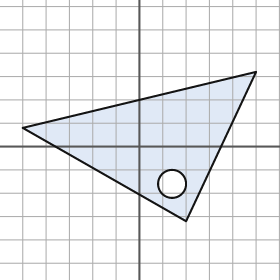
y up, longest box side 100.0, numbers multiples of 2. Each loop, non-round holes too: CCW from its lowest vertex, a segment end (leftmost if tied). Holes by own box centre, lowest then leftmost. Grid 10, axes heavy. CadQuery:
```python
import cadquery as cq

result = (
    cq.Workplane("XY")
    .moveTo(20.0, -32.0)
    .lineTo(50.0, 32.0)
    .lineTo(-50.0, 8.0)
    .close()
    .moveTo(14.0, -16.0)
    .circle(6.0)
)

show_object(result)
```